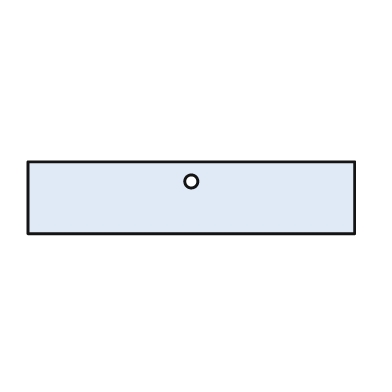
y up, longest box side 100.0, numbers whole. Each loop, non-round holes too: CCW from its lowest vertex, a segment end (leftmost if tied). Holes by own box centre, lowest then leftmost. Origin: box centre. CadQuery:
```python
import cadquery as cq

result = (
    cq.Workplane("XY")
    .moveTo(-50.0, -11.0)
    .lineTo(50.0, -11.0)
    .lineTo(50.0, 11.0)
    .lineTo(-50.0, 11.0)
    .close()
    .moveTo(0.0, 5.0)
    .circle(2.0)
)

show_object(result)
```